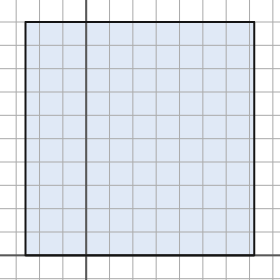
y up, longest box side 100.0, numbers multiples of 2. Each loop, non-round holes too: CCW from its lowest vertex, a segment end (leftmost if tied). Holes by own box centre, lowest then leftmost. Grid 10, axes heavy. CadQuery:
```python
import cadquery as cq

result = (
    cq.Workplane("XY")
    .moveTo(-26.0, 0.0)
    .lineTo(72.0, 0.0)
    .lineTo(72.0, 100.0)
    .lineTo(-26.0, 100.0)
    .close()
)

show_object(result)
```